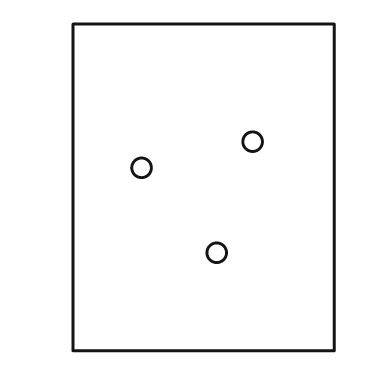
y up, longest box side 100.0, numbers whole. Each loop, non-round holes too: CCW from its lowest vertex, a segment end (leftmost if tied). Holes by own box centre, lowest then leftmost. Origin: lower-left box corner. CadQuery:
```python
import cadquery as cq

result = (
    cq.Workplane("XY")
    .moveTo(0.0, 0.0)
    .lineTo(80.0, 0.0)
    .lineTo(80.0, 100.0)
    .lineTo(0.0, 100.0)
    .close()
    .moveTo(44.0, 30.0)
    .circle(3.0)
    .moveTo(21.0, 56.0)
    .circle(3.0)
    .moveTo(55.0, 64.0)
    .circle(3.0)
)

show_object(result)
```